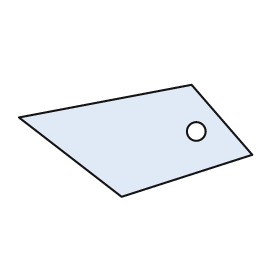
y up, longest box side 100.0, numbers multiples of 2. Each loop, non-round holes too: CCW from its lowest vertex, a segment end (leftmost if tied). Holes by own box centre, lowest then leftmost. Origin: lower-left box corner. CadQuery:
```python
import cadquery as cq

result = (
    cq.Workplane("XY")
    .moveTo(44.0, 0.0)
    .lineTo(100.0, 18.0)
    .lineTo(74.0, 48.0)
    .lineTo(0.0, 34.0)
    .close()
    .moveTo(76.0, 28.0)
    .circle(4.0)
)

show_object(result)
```